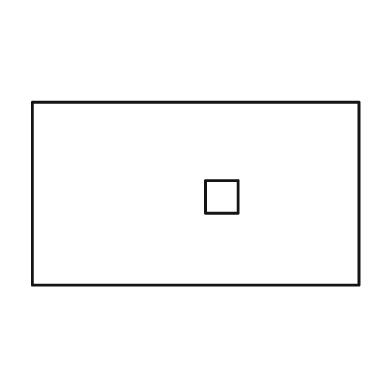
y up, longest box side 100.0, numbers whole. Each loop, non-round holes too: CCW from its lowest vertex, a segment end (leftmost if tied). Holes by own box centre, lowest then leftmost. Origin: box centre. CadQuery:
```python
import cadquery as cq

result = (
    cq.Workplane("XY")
    .moveTo(-50.0, -28.0)
    .lineTo(50.0, -28.0)
    .lineTo(50.0, 28.0)
    .lineTo(-50.0, 28.0)
    .close()
    .moveTo(3.0, -6.0)
    .lineTo(13.0, -6.0)
    .lineTo(13.0, 4.0)
    .lineTo(3.0, 4.0)
    .close()
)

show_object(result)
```